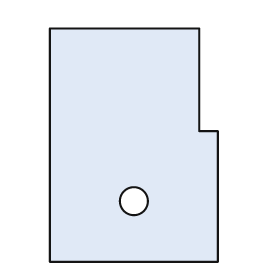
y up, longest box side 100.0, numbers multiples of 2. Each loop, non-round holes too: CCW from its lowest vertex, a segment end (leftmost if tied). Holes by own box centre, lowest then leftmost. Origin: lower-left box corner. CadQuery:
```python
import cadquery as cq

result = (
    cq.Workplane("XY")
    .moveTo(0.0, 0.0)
    .lineTo(72.0, 0.0)
    .lineTo(72.0, 56.0)
    .lineTo(64.0, 56.0)
    .lineTo(64.0, 100.0)
    .lineTo(0.0, 100.0)
    .close()
    .moveTo(36.0, 26.0)
    .circle(6.0)
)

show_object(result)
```